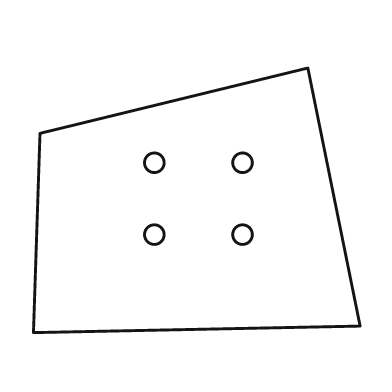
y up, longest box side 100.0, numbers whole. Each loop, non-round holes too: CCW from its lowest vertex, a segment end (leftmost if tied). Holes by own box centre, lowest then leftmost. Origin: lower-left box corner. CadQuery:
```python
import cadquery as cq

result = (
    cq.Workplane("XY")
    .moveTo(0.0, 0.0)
    .lineTo(100.0, 2.0)
    .lineTo(84.0, 81.0)
    .lineTo(2.0, 61.0)
    .close()
    .moveTo(37.0, 30.0)
    .circle(3.0)
    .moveTo(64.0, 30.0)
    .circle(3.0)
    .moveTo(37.0, 52.0)
    .circle(3.0)
    .moveTo(64.0, 52.0)
    .circle(3.0)
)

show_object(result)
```